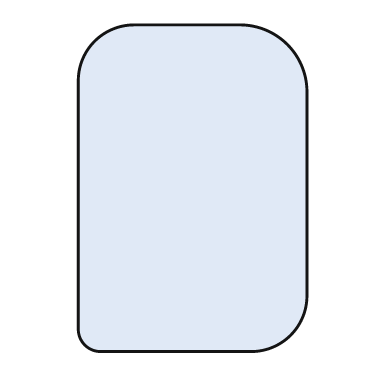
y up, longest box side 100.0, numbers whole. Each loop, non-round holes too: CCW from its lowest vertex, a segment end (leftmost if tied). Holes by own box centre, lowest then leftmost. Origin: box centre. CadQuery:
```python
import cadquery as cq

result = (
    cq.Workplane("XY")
    .moveTo(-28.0, -50.0)
    .lineTo(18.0, -50.0)
    .threePointArc((30.0, -45.0), (35.0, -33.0))
    .lineTo(35.0, 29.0)
    .threePointArc((29.0, 44.0), (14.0, 50.0))
    .lineTo(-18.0, 50.0)
    .threePointArc((-30.0, 45.0), (-35.0, 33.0))
    .lineTo(-35.0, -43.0)
    .threePointArc((-33.0, -48.0), (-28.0, -50.0))
    .close()
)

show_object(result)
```